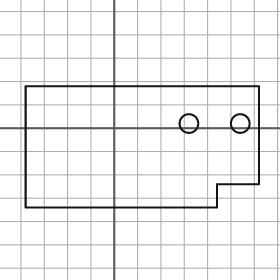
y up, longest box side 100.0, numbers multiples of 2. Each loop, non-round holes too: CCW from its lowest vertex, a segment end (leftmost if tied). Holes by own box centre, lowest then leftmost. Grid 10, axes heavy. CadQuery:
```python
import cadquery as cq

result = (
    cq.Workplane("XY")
    .moveTo(-38.0, -34.0)
    .lineTo(44.0, -34.0)
    .lineTo(44.0, -24.0)
    .lineTo(62.0, -24.0)
    .lineTo(62.0, 18.0)
    .lineTo(-38.0, 18.0)
    .close()
    .moveTo(32.0, 2.0)
    .circle(4.0)
    .moveTo(54.0, 2.0)
    .circle(4.0)
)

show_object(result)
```